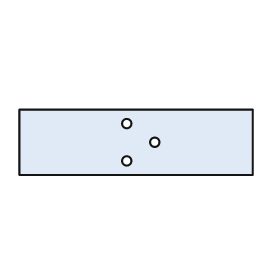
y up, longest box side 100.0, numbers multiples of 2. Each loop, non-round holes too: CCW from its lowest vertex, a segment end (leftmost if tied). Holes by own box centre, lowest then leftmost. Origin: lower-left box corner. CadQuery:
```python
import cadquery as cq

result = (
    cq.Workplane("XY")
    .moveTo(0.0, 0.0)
    .lineTo(100.0, 0.0)
    .lineTo(100.0, 28.0)
    .lineTo(0.0, 28.0)
    .close()
    .moveTo(46.0, 6.0)
    .circle(2.0)
    .moveTo(58.0, 14.0)
    .circle(2.0)
    .moveTo(46.0, 22.0)
    .circle(2.0)
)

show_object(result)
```